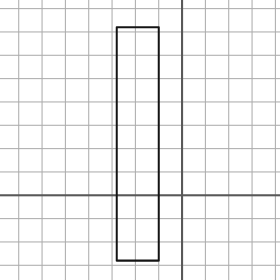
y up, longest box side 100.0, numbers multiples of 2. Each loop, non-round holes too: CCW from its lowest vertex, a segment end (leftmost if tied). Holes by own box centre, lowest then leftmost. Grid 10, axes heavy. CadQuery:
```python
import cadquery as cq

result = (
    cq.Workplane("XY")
    .moveTo(-28.0, -28.0)
    .lineTo(-10.0, -28.0)
    .lineTo(-10.0, 72.0)
    .lineTo(-28.0, 72.0)
    .close()
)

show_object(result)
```